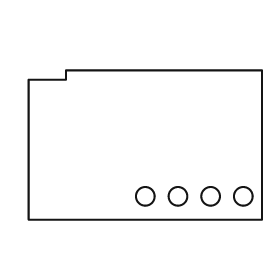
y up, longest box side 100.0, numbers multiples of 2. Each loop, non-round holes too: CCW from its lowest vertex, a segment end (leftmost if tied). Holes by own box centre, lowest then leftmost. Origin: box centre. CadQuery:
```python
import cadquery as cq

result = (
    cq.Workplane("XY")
    .moveTo(-50.0, -32.0)
    .lineTo(50.0, -32.0)
    .lineTo(50.0, 32.0)
    .lineTo(-34.0, 32.0)
    .lineTo(-34.0, 28.0)
    .lineTo(-50.0, 28.0)
    .close()
    .moveTo(0.0, -22.0)
    .circle(4.0)
    .moveTo(14.0, -22.0)
    .circle(4.0)
    .moveTo(28.0, -22.0)
    .circle(4.0)
    .moveTo(42.0, -22.0)
    .circle(4.0)
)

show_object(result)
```